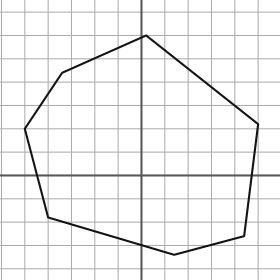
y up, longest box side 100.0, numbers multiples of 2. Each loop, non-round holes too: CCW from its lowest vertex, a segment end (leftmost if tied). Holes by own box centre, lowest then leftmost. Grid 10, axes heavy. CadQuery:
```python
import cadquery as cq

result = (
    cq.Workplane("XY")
    .moveTo(14.0, -34.0)
    .lineTo(44.0, -26.0)
    .lineTo(50.0, 22.0)
    .lineTo(2.0, 60.0)
    .lineTo(-34.0, 44.0)
    .lineTo(-50.0, 20.0)
    .lineTo(-40.0, -18.0)
    .close()
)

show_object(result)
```